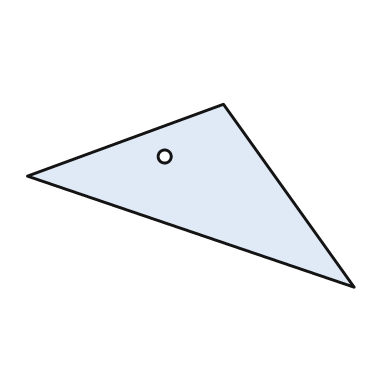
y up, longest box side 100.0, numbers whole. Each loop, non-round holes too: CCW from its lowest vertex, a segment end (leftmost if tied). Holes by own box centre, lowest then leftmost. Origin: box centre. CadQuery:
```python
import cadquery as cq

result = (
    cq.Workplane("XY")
    .moveTo(50.0, -28.0)
    .lineTo(10.0, 28.0)
    .lineTo(-50.0, 6.0)
    .close()
    .moveTo(-8.0, 12.0)
    .circle(2.0)
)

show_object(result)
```